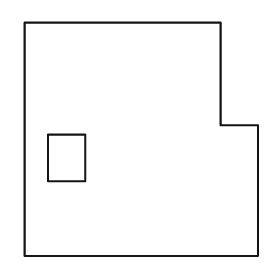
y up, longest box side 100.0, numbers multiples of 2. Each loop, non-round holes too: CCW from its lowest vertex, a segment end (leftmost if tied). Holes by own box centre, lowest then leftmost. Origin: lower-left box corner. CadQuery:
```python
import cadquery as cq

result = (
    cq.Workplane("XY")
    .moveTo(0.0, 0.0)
    .lineTo(100.0, 0.0)
    .lineTo(100.0, 56.0)
    .lineTo(84.0, 56.0)
    .lineTo(84.0, 100.0)
    .lineTo(0.0, 100.0)
    .close()
    .moveTo(10.0, 32.0)
    .lineTo(26.0, 32.0)
    .lineTo(26.0, 52.0)
    .lineTo(10.0, 52.0)
    .close()
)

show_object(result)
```